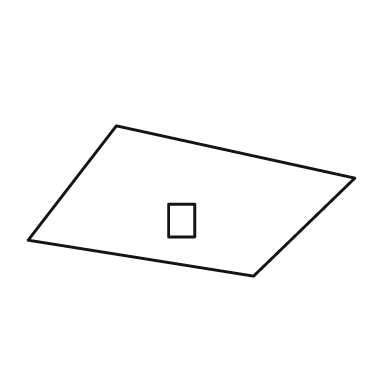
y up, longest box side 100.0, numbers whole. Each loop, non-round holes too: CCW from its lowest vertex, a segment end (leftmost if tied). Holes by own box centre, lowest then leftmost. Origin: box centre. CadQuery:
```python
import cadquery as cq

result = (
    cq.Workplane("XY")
    .moveTo(19.0, -23.0)
    .lineTo(50.0, 7.0)
    .lineTo(-23.0, 23.0)
    .lineTo(-50.0, -12.0)
    .close()
    .moveTo(-7.0, -11.0)
    .lineTo(1.0, -11.0)
    .lineTo(1.0, -1.0)
    .lineTo(-7.0, -1.0)
    .close()
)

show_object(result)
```